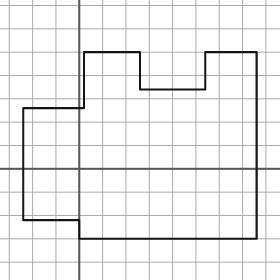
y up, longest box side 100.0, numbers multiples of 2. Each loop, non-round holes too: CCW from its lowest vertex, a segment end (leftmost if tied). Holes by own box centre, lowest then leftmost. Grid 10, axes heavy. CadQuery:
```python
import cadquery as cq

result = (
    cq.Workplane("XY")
    .moveTo(0.0, -30.0)
    .lineTo(76.0, -30.0)
    .lineTo(76.0, 50.0)
    .lineTo(54.0, 50.0)
    .lineTo(54.0, 34.0)
    .lineTo(26.0, 34.0)
    .lineTo(26.0, 50.0)
    .lineTo(2.0, 50.0)
    .lineTo(2.0, 26.0)
    .lineTo(-24.0, 26.0)
    .lineTo(-24.0, -22.0)
    .lineTo(0.0, -22.0)
    .close()
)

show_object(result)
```